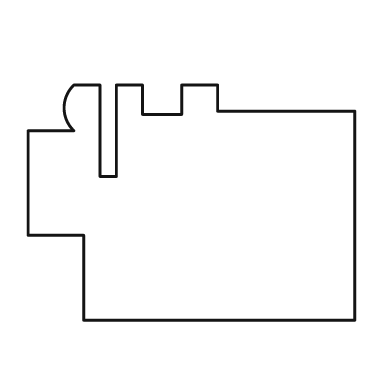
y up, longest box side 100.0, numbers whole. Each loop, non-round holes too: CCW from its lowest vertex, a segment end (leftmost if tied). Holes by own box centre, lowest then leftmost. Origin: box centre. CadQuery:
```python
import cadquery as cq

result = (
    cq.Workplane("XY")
    .moveTo(-33.0, -36.0)
    .lineTo(50.0, -36.0)
    .lineTo(50.0, 28.0)
    .lineTo(8.0, 28.0)
    .lineTo(8.0, 36.0)
    .lineTo(-3.0, 36.0)
    .lineTo(-3.0, 27.0)
    .lineTo(-15.0, 27.0)
    .lineTo(-15.0, 36.0)
    .lineTo(-23.0, 36.0)
    .lineTo(-23.0, 8.0)
    .lineTo(-28.0, 8.0)
    .lineTo(-28.0, 36.0)
    .lineTo(-36.0, 36.0)
    .threePointArc((-39.0, 29.0), (-36.0, 22.0))
    .lineTo(-50.0, 22.0)
    .lineTo(-50.0, -10.0)
    .lineTo(-33.0, -10.0)
    .close()
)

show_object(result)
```